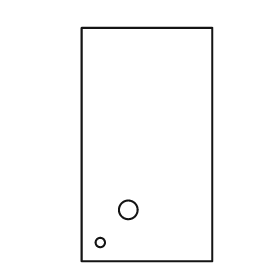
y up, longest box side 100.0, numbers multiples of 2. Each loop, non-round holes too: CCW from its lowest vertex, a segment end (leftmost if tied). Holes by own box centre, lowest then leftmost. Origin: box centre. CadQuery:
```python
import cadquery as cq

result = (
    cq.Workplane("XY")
    .moveTo(-28.0, -50.0)
    .lineTo(28.0, -50.0)
    .lineTo(28.0, 50.0)
    .lineTo(-28.0, 50.0)
    .close()
    .moveTo(-20.0, -42.0)
    .circle(2.0)
    .moveTo(-8.0, -28.0)
    .circle(4.0)
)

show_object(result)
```